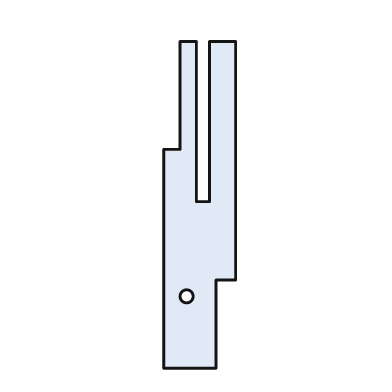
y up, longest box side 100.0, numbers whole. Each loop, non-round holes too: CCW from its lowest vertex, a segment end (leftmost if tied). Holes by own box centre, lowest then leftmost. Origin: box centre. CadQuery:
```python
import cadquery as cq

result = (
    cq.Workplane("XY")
    .moveTo(-11.0, -50.0)
    .lineTo(5.0, -50.0)
    .lineTo(5.0, -23.0)
    .lineTo(11.0, -23.0)
    .lineTo(11.0, 50.0)
    .lineTo(3.0, 50.0)
    .lineTo(3.0, 1.0)
    .lineTo(-1.0, 1.0)
    .lineTo(-1.0, 50.0)
    .lineTo(-6.0, 50.0)
    .lineTo(-6.0, 17.0)
    .lineTo(-11.0, 17.0)
    .close()
    .moveTo(-4.0, -28.0)
    .circle(2.0)
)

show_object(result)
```